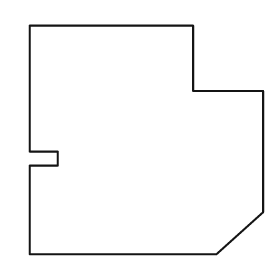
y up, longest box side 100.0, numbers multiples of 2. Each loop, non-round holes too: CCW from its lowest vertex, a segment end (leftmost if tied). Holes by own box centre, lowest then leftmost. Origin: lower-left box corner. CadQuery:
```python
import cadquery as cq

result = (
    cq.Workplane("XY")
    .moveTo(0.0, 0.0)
    .lineTo(80.0, 0.0)
    .lineTo(100.0, 18.0)
    .lineTo(100.0, 70.0)
    .lineTo(70.0, 70.0)
    .lineTo(70.0, 98.0)
    .lineTo(0.0, 98.0)
    .lineTo(0.0, 44.0)
    .lineTo(12.0, 44.0)
    .lineTo(12.0, 38.0)
    .lineTo(0.0, 38.0)
    .close()
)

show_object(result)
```